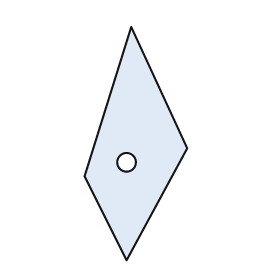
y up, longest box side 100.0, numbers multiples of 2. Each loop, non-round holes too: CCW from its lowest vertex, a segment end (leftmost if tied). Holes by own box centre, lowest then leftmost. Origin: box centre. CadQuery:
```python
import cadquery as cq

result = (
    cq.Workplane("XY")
    .moveTo(-4.0, -50.0)
    .lineTo(22.0, -2.0)
    .lineTo(-2.0, 50.0)
    .lineTo(-22.0, -14.0)
    .close()
    .moveTo(-4.0, -8.0)
    .circle(4.0)
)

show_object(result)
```